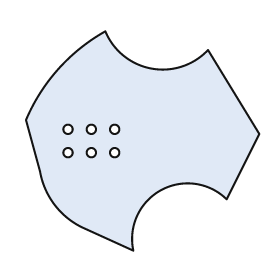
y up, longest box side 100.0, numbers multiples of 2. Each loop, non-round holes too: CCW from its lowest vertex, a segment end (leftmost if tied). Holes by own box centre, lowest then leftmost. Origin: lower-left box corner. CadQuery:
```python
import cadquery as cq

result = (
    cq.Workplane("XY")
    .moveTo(46.0, 0.0)
    .threePointArc((58.0, 26.0), (86.0, 22.0))
    .lineTo(100.0, 50.0)
    .lineTo(78.0, 86.0)
    .threePointArc((54.0, 78.0), (34.0, 94.0))
    .threePointArc((14.0, 78.0), (0.0, 56.0))
    .lineTo(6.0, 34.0)
    .threePointArc((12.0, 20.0), (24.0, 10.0))
    .close()
    .moveTo(18.0, 42.0)
    .circle(2.0)
    .moveTo(28.0, 42.0)
    .circle(2.0)
    .moveTo(38.0, 42.0)
    .circle(2.0)
    .moveTo(18.0, 52.0)
    .circle(2.0)
    .moveTo(28.0, 52.0)
    .circle(2.0)
    .moveTo(38.0, 52.0)
    .circle(2.0)
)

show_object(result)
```